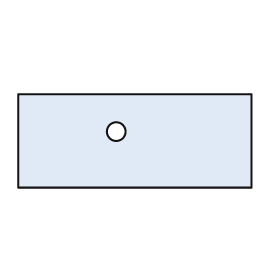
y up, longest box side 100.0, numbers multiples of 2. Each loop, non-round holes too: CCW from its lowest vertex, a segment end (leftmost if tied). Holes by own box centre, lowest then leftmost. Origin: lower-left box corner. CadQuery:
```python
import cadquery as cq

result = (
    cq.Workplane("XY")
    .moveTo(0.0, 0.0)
    .lineTo(100.0, 0.0)
    .lineTo(100.0, 40.0)
    .lineTo(0.0, 40.0)
    .close()
    .moveTo(42.0, 24.0)
    .circle(4.0)
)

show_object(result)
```